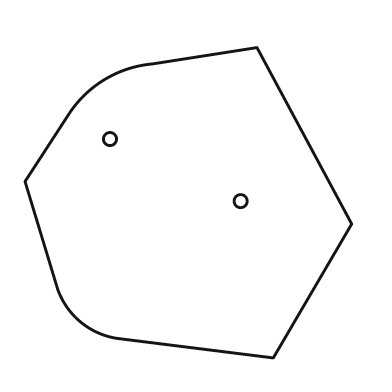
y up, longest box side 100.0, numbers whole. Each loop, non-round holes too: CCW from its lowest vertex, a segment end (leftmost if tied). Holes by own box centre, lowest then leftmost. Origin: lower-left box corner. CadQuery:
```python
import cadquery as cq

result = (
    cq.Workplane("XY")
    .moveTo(76.0, 0.0)
    .lineTo(100.0, 41.0)
    .lineTo(71.0, 95.0)
    .lineTo(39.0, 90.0)
    .threePointArc((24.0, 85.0), (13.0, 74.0))
    .lineTo(0.0, 54.0)
    .lineTo(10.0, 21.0)
    .threePointArc((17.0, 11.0), (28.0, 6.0))
    .close()
    .moveTo(66.0, 48.0)
    .circle(2.0)
    .moveTo(26.0, 67.0)
    .circle(2.0)
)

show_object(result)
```